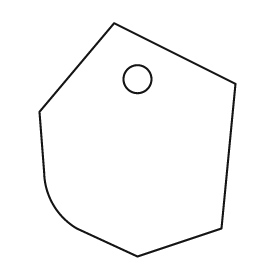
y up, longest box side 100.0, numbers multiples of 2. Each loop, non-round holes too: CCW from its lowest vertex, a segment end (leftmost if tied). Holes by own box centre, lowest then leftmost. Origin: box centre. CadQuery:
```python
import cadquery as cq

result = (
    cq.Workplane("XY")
    .moveTo(0.0, -50.0)
    .lineTo(36.0, -38.0)
    .lineTo(42.0, 24.0)
    .lineTo(-10.0, 50.0)
    .lineTo(-42.0, 12.0)
    .lineTo(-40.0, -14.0)
    .threePointArc((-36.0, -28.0), (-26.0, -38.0))
    .close()
    .moveTo(0.0, 26.0)
    .circle(6.0)
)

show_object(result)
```